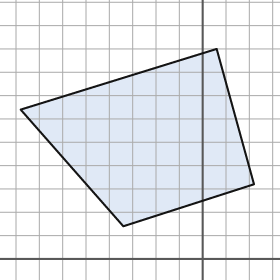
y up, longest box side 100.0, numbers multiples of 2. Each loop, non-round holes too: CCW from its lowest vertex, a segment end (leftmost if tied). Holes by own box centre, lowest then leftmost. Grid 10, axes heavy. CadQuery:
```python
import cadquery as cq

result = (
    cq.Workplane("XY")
    .moveTo(-34.0, 14.0)
    .lineTo(22.0, 32.0)
    .lineTo(6.0, 90.0)
    .lineTo(-78.0, 64.0)
    .close()
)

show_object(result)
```